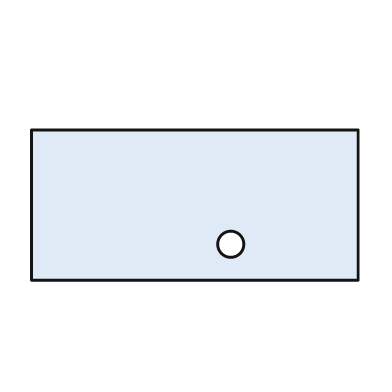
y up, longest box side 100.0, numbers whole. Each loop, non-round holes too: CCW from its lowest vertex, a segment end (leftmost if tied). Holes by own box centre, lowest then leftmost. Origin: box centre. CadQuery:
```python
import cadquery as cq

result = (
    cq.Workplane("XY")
    .moveTo(-50.0, -23.0)
    .lineTo(50.0, -23.0)
    .lineTo(50.0, 23.0)
    .lineTo(-50.0, 23.0)
    .close()
    .moveTo(11.0, -12.0)
    .circle(4.0)
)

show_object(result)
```